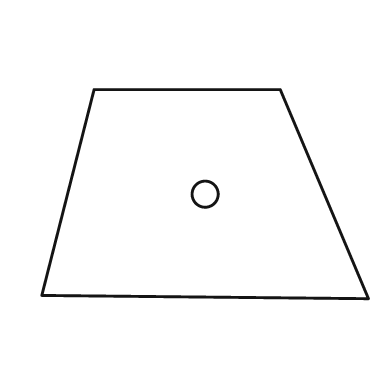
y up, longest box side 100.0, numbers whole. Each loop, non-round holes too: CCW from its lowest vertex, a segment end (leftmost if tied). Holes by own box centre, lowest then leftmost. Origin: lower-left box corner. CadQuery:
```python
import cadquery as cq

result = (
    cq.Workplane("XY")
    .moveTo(100.0, 0.0)
    .lineTo(73.0, 64.0)
    .lineTo(16.0, 64.0)
    .lineTo(0.0, 1.0)
    .close()
    .moveTo(50.0, 32.0)
    .circle(4.0)
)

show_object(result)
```